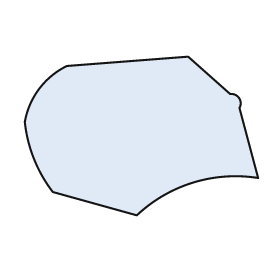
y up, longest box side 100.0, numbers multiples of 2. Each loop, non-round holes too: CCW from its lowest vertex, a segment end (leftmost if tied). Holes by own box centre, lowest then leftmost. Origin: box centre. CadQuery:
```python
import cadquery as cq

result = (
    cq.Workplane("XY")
    .moveTo(-2.0, -34.0)
    .threePointArc((22.0, -20.0), (50.0, -18.0))
    .lineTo(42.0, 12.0)
    .threePointArc((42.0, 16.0), (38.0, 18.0))
    .lineTo(20.0, 34.0)
    .lineTo(-32.0, 30.0)
    .threePointArc((-44.0, 20.0), (-50.0, 6.0))
    .threePointArc((-46.0, -10.0), (-38.0, -24.0))
    .close()
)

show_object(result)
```